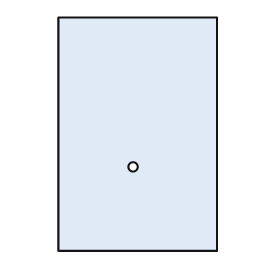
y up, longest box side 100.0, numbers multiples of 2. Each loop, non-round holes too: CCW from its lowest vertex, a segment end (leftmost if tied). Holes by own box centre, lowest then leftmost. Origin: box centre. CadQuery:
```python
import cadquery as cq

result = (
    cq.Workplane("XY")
    .moveTo(-34.0, -50.0)
    .lineTo(34.0, -50.0)
    .lineTo(34.0, 50.0)
    .lineTo(-34.0, 50.0)
    .close()
    .moveTo(-2.0, -14.0)
    .circle(2.0)
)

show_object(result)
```